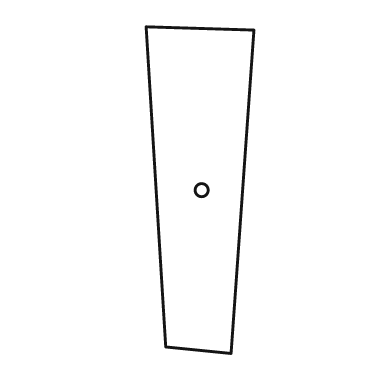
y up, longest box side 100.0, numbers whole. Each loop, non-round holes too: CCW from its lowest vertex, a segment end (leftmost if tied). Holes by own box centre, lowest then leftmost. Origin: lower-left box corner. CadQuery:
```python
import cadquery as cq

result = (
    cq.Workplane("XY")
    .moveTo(26.0, 0.0)
    .lineTo(33.0, 99.0)
    .lineTo(0.0, 100.0)
    .lineTo(6.0, 2.0)
    .close()
    .moveTo(17.0, 50.0)
    .circle(2.0)
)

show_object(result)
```